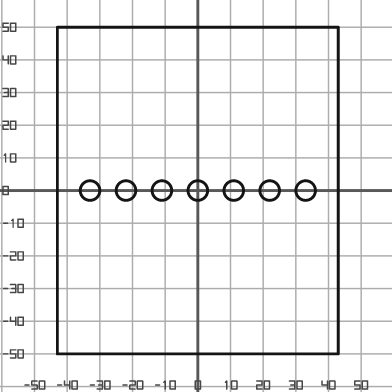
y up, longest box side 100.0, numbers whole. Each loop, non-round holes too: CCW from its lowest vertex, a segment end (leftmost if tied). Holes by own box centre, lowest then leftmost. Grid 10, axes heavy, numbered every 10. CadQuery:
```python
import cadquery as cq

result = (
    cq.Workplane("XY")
    .moveTo(-43.0, -50.0)
    .lineTo(43.0, -50.0)
    .lineTo(43.0, 50.0)
    .lineTo(-43.0, 50.0)
    .close()
    .moveTo(-33.0, 0.0)
    .circle(3.0)
    .moveTo(-22.0, 0.0)
    .circle(3.0)
    .moveTo(-11.0, 0.0)
    .circle(3.0)
    .moveTo(0.0, 0.0)
    .circle(3.0)
    .moveTo(11.0, 0.0)
    .circle(3.0)
    .moveTo(22.0, 0.0)
    .circle(3.0)
    .moveTo(33.0, 0.0)
    .circle(3.0)
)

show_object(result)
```